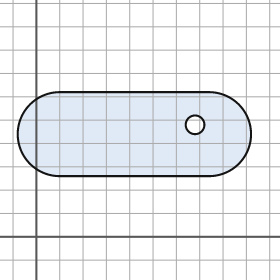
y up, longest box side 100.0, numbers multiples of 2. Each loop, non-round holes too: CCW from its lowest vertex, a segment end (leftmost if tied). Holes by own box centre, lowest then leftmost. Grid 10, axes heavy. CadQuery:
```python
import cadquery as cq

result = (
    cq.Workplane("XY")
    .moveTo(10.0, 26.0)
    .lineTo(74.0, 26.0)
    .threePointArc((92.0, 44.0), (74.0, 62.0))
    .lineTo(10.0, 62.0)
    .threePointArc((-8.0, 44.0), (10.0, 26.0))
    .close()
    .moveTo(68.0, 48.0)
    .circle(4.0)
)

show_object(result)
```